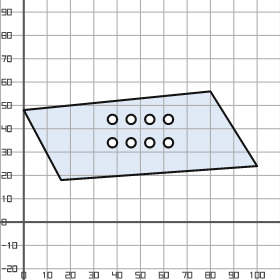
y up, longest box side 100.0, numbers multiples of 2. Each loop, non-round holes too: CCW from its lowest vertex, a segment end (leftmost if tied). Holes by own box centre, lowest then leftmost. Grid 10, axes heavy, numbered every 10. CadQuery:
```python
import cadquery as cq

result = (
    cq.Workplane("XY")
    .moveTo(16.0, 18.0)
    .lineTo(100.0, 24.0)
    .lineTo(80.0, 56.0)
    .lineTo(0.0, 48.0)
    .close()
    .moveTo(38.0, 34.0)
    .circle(2.0)
    .moveTo(46.0, 34.0)
    .circle(2.0)
    .moveTo(54.0, 34.0)
    .circle(2.0)
    .moveTo(62.0, 34.0)
    .circle(2.0)
    .moveTo(38.0, 44.0)
    .circle(2.0)
    .moveTo(46.0, 44.0)
    .circle(2.0)
    .moveTo(54.0, 44.0)
    .circle(2.0)
    .moveTo(62.0, 44.0)
    .circle(2.0)
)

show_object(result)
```